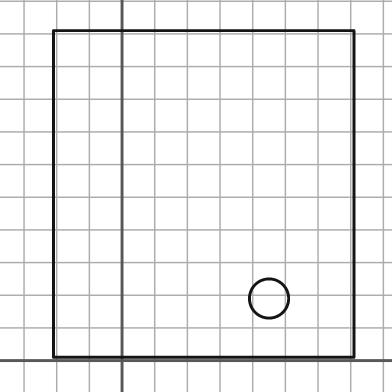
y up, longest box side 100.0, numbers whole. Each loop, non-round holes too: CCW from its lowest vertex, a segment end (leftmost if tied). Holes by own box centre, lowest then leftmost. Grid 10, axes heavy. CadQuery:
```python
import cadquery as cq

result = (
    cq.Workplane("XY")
    .moveTo(-21.0, 1.0)
    .lineTo(71.0, 1.0)
    .lineTo(71.0, 101.0)
    .lineTo(-21.0, 101.0)
    .close()
    .moveTo(45.0, 19.0)
    .circle(6.0)
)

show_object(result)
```